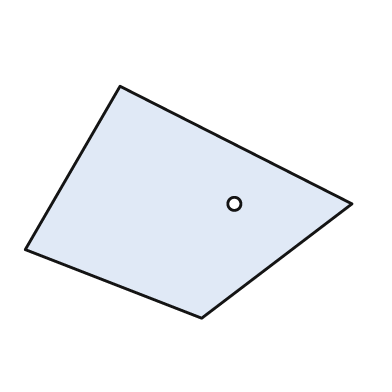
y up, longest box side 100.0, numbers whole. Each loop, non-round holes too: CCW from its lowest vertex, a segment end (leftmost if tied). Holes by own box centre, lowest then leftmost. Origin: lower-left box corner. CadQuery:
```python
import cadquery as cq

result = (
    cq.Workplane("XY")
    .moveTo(54.0, 0.0)
    .lineTo(100.0, 35.0)
    .lineTo(29.0, 71.0)
    .lineTo(0.0, 21.0)
    .close()
    .moveTo(64.0, 35.0)
    .circle(2.0)
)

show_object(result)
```